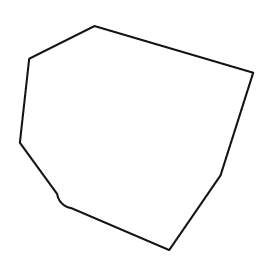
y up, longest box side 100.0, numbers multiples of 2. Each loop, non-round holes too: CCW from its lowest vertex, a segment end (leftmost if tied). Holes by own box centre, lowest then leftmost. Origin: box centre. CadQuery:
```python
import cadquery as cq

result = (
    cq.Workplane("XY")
    .moveTo(14.0, -48.0)
    .lineTo(36.0, -16.0)
    .lineTo(50.0, 28.0)
    .lineTo(-18.0, 48.0)
    .lineTo(-46.0, 34.0)
    .lineTo(-50.0, -2.0)
    .lineTo(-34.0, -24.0)
    .threePointArc((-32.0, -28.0), (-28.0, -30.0))
    .close()
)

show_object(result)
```